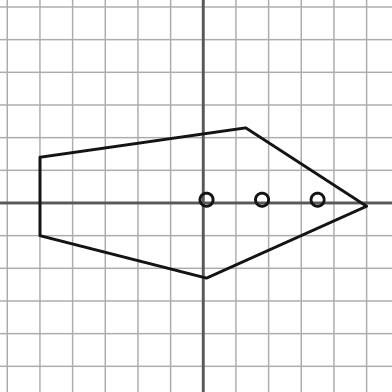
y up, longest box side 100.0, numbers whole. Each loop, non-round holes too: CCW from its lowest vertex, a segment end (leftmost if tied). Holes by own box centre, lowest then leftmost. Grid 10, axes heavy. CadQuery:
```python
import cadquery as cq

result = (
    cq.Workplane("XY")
    .moveTo(1.0, -23.0)
    .lineTo(50.0, -1.0)
    .lineTo(13.0, 23.0)
    .lineTo(-50.0, 14.0)
    .lineTo(-50.0, -10.0)
    .close()
    .moveTo(1.0, 1.0)
    .circle(2.0)
    .moveTo(18.0, 1.0)
    .circle(2.0)
    .moveTo(35.0, 1.0)
    .circle(2.0)
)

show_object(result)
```